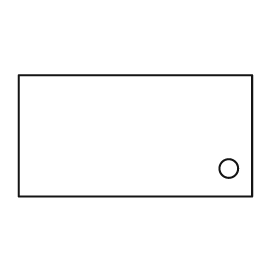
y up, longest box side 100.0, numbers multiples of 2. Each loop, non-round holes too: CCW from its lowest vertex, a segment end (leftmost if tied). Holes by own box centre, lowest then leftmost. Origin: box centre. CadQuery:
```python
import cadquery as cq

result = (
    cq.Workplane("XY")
    .moveTo(-50.0, -26.0)
    .lineTo(50.0, -26.0)
    .lineTo(50.0, 26.0)
    .lineTo(-50.0, 26.0)
    .close()
    .moveTo(40.0, -14.0)
    .circle(4.0)
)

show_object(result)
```